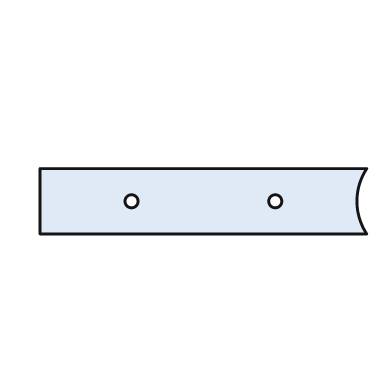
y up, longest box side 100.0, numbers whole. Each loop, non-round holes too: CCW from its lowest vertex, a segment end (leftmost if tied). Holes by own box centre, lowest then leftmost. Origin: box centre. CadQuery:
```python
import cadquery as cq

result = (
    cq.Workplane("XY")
    .moveTo(-50.0, -10.0)
    .lineTo(50.0, -10.0)
    .threePointArc((47.0, 0.0), (50.0, 10.0))
    .lineTo(-50.0, 10.0)
    .close()
    .moveTo(-22.0, 0.0)
    .circle(2.0)
    .moveTo(22.0, 0.0)
    .circle(2.0)
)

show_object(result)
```